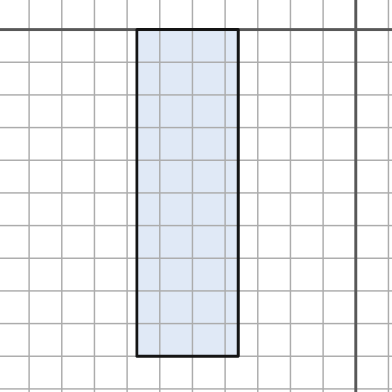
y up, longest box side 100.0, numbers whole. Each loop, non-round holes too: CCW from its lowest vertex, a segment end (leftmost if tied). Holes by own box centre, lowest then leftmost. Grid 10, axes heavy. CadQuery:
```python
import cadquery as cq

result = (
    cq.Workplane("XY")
    .moveTo(-67.0, -100.0)
    .lineTo(-36.0, -100.0)
    .lineTo(-36.0, 0.0)
    .lineTo(-67.0, 0.0)
    .close()
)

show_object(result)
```